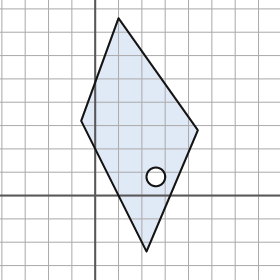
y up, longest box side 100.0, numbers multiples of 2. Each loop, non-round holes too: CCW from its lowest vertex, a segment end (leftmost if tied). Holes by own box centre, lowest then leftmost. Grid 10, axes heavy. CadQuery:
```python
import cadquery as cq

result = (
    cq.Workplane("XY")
    .moveTo(22.0, -24.0)
    .lineTo(44.0, 28.0)
    .lineTo(10.0, 76.0)
    .lineTo(-6.0, 32.0)
    .close()
    .moveTo(26.0, 8.0)
    .circle(4.0)
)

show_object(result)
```